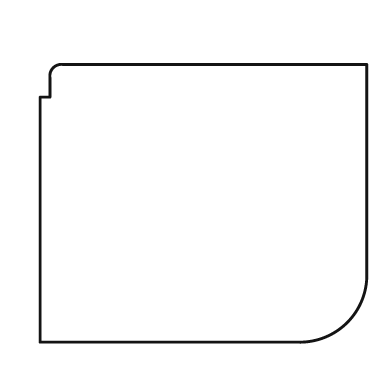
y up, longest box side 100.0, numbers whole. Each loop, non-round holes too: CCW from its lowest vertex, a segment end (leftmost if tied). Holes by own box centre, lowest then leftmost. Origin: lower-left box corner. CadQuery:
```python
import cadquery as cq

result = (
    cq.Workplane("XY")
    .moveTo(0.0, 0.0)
    .lineTo(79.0, 0.0)
    .threePointArc((94.0, 6.0), (100.0, 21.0))
    .lineTo(100.0, 85.0)
    .lineTo(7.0, 85.0)
    .threePointArc((4.0, 84.0), (3.0, 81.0))
    .lineTo(3.0, 75.0)
    .lineTo(0.0, 75.0)
    .close()
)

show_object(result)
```